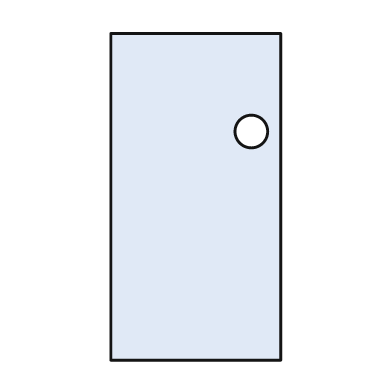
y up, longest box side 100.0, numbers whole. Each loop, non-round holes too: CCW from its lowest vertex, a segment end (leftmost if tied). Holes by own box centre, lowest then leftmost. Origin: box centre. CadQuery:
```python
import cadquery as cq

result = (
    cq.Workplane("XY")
    .moveTo(-26.0, -50.0)
    .lineTo(26.0, -50.0)
    .lineTo(26.0, 50.0)
    .lineTo(-26.0, 50.0)
    .close()
    .moveTo(17.0, 20.0)
    .circle(5.0)
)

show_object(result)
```